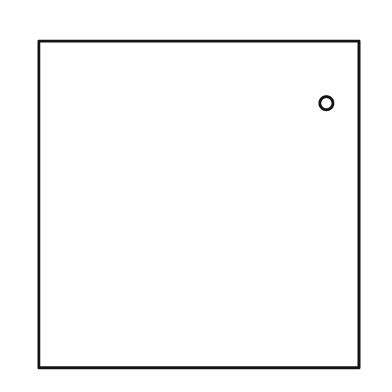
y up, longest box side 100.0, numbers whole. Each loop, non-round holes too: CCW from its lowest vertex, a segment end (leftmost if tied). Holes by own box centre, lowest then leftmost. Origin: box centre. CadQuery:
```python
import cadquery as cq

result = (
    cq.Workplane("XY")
    .moveTo(-49.0, -50.0)
    .lineTo(49.0, -50.0)
    .lineTo(49.0, 50.0)
    .lineTo(-49.0, 50.0)
    .close()
    .moveTo(39.0, 31.0)
    .circle(2.0)
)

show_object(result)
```